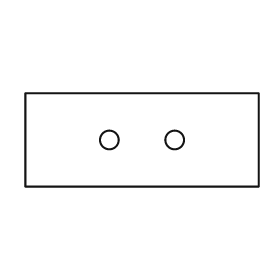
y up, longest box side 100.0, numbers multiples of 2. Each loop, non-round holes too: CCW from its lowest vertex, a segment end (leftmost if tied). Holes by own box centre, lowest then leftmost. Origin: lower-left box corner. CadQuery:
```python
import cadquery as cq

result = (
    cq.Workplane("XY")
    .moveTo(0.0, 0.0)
    .lineTo(100.0, 0.0)
    .lineTo(100.0, 40.0)
    .lineTo(0.0, 40.0)
    .close()
    .moveTo(36.0, 20.0)
    .circle(4.0)
    .moveTo(64.0, 20.0)
    .circle(4.0)
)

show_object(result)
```